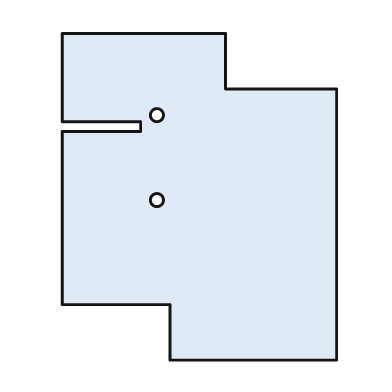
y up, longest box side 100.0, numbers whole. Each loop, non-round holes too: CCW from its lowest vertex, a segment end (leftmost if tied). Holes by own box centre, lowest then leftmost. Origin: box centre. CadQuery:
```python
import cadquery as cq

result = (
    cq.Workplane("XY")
    .moveTo(-9.0, -50.0)
    .lineTo(42.0, -50.0)
    .lineTo(42.0, 33.0)
    .lineTo(8.0, 33.0)
    .lineTo(8.0, 50.0)
    .lineTo(-42.0, 50.0)
    .lineTo(-42.0, 23.0)
    .lineTo(-18.0, 23.0)
    .lineTo(-18.0, 20.0)
    .lineTo(-42.0, 20.0)
    .lineTo(-42.0, -33.0)
    .lineTo(-9.0, -33.0)
    .close()
    .moveTo(-13.0, -1.0)
    .circle(2.0)
    .moveTo(-13.0, 25.0)
    .circle(2.0)
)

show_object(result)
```